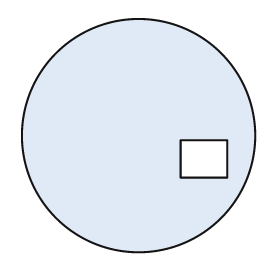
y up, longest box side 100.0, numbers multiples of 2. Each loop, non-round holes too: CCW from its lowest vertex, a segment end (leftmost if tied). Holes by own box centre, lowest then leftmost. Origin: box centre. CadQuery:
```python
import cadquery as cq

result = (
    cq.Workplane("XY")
    .moveTo(0.0, 0.0)
    .circle(50.0)
    .moveTo(18.0, -18.0)
    .lineTo(38.0, -18.0)
    .lineTo(38.0, -2.0)
    .lineTo(18.0, -2.0)
    .close()
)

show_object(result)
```